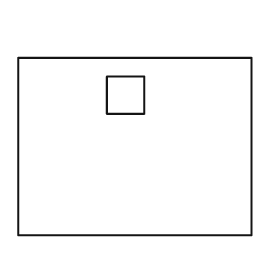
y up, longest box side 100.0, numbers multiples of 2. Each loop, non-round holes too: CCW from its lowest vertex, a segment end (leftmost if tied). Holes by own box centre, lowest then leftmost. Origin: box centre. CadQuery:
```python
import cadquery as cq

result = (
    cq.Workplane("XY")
    .moveTo(-50.0, -38.0)
    .lineTo(50.0, -38.0)
    .lineTo(50.0, 38.0)
    .lineTo(-50.0, 38.0)
    .close()
    .moveTo(-12.0, 14.0)
    .lineTo(4.0, 14.0)
    .lineTo(4.0, 30.0)
    .lineTo(-12.0, 30.0)
    .close()
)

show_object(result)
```